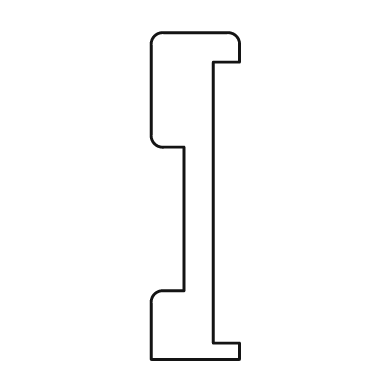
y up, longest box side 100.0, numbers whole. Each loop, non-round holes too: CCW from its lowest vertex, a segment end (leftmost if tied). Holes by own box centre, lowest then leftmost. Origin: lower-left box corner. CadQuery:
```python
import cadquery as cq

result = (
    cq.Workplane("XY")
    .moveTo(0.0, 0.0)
    .lineTo(27.0, 0.0)
    .lineTo(27.0, 5.0)
    .lineTo(19.0, 5.0)
    .lineTo(19.0, 91.0)
    .lineTo(27.0, 91.0)
    .lineTo(27.0, 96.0)
    .threePointArc((26.0, 99.0), (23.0, 100.0))
    .lineTo(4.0, 100.0)
    .threePointArc((1.0, 99.0), (0.0, 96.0))
    .lineTo(0.0, 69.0)
    .threePointArc((1.0, 66.0), (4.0, 65.0))
    .lineTo(10.0, 65.0)
    .lineTo(10.0, 21.0)
    .lineTo(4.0, 21.0)
    .threePointArc((1.0, 20.0), (0.0, 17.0))
    .close()
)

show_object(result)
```